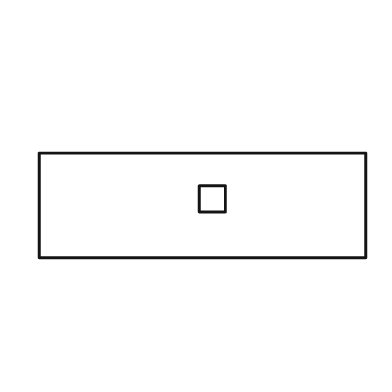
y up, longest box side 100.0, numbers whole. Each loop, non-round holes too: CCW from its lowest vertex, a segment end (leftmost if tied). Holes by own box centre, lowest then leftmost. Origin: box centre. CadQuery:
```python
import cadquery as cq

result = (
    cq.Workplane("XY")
    .moveTo(-50.0, -16.0)
    .lineTo(50.0, -16.0)
    .lineTo(50.0, 16.0)
    .lineTo(-50.0, 16.0)
    .close()
    .moveTo(-1.0, -2.0)
    .lineTo(7.0, -2.0)
    .lineTo(7.0, 6.0)
    .lineTo(-1.0, 6.0)
    .close()
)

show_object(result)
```